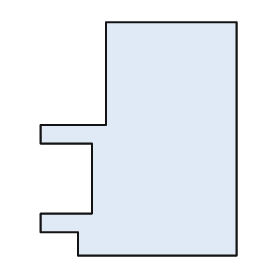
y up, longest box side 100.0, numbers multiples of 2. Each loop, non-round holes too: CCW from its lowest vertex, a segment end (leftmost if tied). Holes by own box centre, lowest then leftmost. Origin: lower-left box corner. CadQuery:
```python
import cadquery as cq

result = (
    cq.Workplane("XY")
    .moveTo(16.0, 0.0)
    .lineTo(84.0, 0.0)
    .lineTo(84.0, 100.0)
    .lineTo(28.0, 100.0)
    .lineTo(28.0, 56.0)
    .lineTo(0.0, 56.0)
    .lineTo(0.0, 48.0)
    .lineTo(22.0, 48.0)
    .lineTo(22.0, 18.0)
    .lineTo(0.0, 18.0)
    .lineTo(0.0, 10.0)
    .lineTo(16.0, 10.0)
    .close()
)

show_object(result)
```